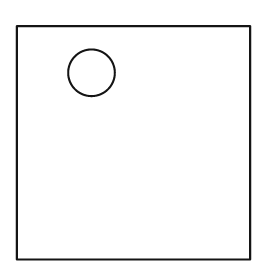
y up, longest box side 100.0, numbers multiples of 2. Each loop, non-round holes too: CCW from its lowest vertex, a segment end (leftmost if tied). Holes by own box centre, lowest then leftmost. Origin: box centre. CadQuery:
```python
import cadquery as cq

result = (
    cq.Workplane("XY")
    .moveTo(-50.0, -50.0)
    .lineTo(50.0, -50.0)
    .lineTo(50.0, 50.0)
    .lineTo(-50.0, 50.0)
    .close()
    .moveTo(-18.0, 30.0)
    .circle(10.0)
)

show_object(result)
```